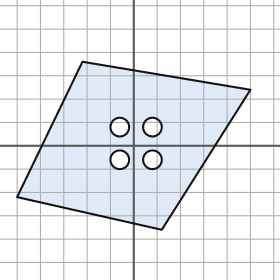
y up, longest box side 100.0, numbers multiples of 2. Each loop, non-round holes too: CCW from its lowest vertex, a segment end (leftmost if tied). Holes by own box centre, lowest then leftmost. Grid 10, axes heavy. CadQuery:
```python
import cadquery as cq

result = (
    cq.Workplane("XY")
    .moveTo(12.0, -36.0)
    .lineTo(50.0, 24.0)
    .lineTo(-22.0, 36.0)
    .lineTo(-50.0, -22.0)
    .close()
    .moveTo(-6.0, -6.0)
    .circle(4.0)
    .moveTo(8.0, -6.0)
    .circle(4.0)
    .moveTo(-6.0, 8.0)
    .circle(4.0)
    .moveTo(8.0, 8.0)
    .circle(4.0)
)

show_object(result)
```